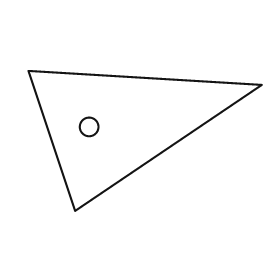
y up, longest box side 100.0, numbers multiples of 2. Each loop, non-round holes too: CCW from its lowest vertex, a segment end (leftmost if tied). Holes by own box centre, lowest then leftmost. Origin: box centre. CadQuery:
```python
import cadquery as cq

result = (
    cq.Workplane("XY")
    .moveTo(-30.0, -30.0)
    .lineTo(50.0, 24.0)
    .lineTo(-50.0, 30.0)
    .close()
    .moveTo(-24.0, 6.0)
    .circle(4.0)
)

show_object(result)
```